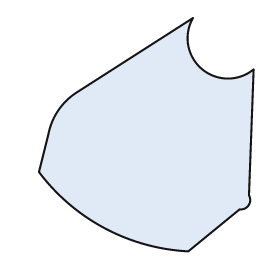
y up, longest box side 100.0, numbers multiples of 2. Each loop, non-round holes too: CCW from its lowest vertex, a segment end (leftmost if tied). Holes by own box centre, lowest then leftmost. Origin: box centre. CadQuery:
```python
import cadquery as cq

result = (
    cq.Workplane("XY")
    .moveTo(18.0, -50.0)
    .lineTo(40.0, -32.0)
    .threePointArc((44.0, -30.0), (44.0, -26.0))
    .lineTo(46.0, 28.0)
    .threePointArc((24.0, 28.0), (20.0, 50.0))
    .lineTo(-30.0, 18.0)
    .threePointArc((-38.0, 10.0), (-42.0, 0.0))
    .lineTo(-46.0, -16.0)
    .threePointArc((-18.0, -40.0), (18.0, -50.0))
    .close()
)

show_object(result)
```